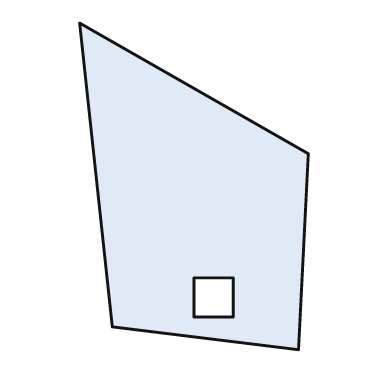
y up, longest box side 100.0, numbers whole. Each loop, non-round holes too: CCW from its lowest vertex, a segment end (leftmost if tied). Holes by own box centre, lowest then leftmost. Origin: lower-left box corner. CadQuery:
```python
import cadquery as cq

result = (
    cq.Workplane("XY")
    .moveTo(67.0, 0.0)
    .lineTo(70.0, 60.0)
    .lineTo(0.0, 100.0)
    .lineTo(10.0, 7.0)
    .close()
    .moveTo(35.0, 10.0)
    .lineTo(47.0, 10.0)
    .lineTo(47.0, 22.0)
    .lineTo(35.0, 22.0)
    .close()
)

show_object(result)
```